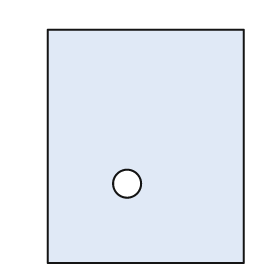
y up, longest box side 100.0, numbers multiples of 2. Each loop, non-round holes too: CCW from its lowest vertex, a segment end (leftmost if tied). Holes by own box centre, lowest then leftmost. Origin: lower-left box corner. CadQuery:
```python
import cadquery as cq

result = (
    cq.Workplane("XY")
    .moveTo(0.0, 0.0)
    .lineTo(84.0, 0.0)
    .lineTo(84.0, 100.0)
    .lineTo(0.0, 100.0)
    .close()
    .moveTo(34.0, 34.0)
    .circle(6.0)
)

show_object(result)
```